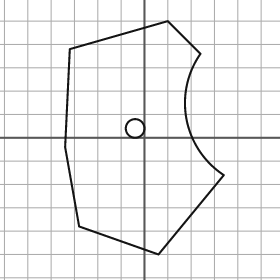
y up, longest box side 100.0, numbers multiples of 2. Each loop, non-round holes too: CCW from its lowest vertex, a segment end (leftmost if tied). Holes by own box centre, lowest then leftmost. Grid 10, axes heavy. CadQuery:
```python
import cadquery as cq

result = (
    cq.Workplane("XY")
    .moveTo(6.0, -50.0)
    .lineTo(34.0, -16.0)
    .threePointArc((18.0, 8.0), (24.0, 36.0))
    .lineTo(10.0, 50.0)
    .lineTo(-32.0, 38.0)
    .lineTo(-34.0, -4.0)
    .lineTo(-28.0, -38.0)
    .close()
    .moveTo(-4.0, 4.0)
    .circle(4.0)
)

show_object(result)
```